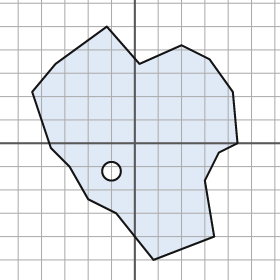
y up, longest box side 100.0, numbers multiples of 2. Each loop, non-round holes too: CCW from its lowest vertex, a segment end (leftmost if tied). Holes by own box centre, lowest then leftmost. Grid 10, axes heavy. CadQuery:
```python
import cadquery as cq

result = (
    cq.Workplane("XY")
    .moveTo(8.0, -50.0)
    .lineTo(34.0, -40.0)
    .lineTo(30.0, -16.0)
    .lineTo(36.0, -4.0)
    .lineTo(44.0, 0.0)
    .lineTo(42.0, 22.0)
    .lineTo(32.0, 36.0)
    .lineTo(20.0, 42.0)
    .lineTo(2.0, 34.0)
    .lineTo(-12.0, 50.0)
    .lineTo(-34.0, 34.0)
    .lineTo(-44.0, 22.0)
    .lineTo(-36.0, -2.0)
    .lineTo(-28.0, -10.0)
    .lineTo(-20.0, -24.0)
    .lineTo(-8.0, -30.0)
    .close()
    .moveTo(-10.0, -12.0)
    .circle(4.0)
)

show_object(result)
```